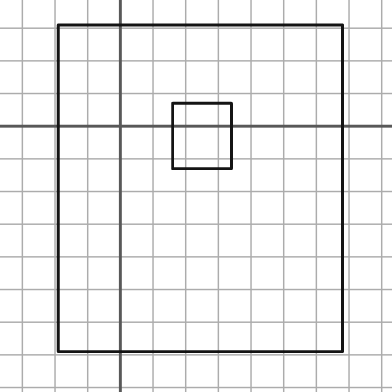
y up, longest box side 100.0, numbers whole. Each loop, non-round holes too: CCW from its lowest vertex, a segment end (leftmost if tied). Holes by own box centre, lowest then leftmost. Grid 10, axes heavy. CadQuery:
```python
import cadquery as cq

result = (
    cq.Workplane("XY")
    .moveTo(-19.0, -69.0)
    .lineTo(68.0, -69.0)
    .lineTo(68.0, 31.0)
    .lineTo(-19.0, 31.0)
    .close()
    .moveTo(16.0, -13.0)
    .lineTo(34.0, -13.0)
    .lineTo(34.0, 7.0)
    .lineTo(16.0, 7.0)
    .close()
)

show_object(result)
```